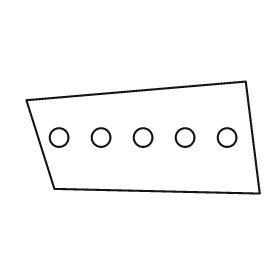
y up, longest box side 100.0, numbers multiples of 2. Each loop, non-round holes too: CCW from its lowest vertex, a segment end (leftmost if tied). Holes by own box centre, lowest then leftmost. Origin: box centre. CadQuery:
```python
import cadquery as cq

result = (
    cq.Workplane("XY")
    .moveTo(50.0, -24.0)
    .lineTo(44.0, 24.0)
    .lineTo(-50.0, 16.0)
    .lineTo(-38.0, -22.0)
    .close()
    .moveTo(-36.0, 0.0)
    .circle(4.0)
    .moveTo(-18.0, 0.0)
    .circle(4.0)
    .moveTo(0.0, 0.0)
    .circle(4.0)
    .moveTo(18.0, 0.0)
    .circle(4.0)
    .moveTo(36.0, 0.0)
    .circle(4.0)
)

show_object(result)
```